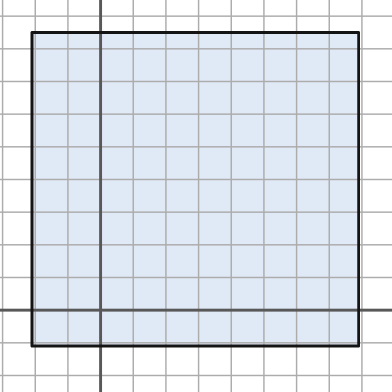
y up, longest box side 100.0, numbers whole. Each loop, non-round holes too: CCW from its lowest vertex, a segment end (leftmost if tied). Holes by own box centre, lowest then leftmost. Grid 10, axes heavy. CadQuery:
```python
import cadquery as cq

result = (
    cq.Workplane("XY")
    .moveTo(-21.0, -11.0)
    .lineTo(79.0, -11.0)
    .lineTo(79.0, 85.0)
    .lineTo(-21.0, 85.0)
    .close()
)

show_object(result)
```